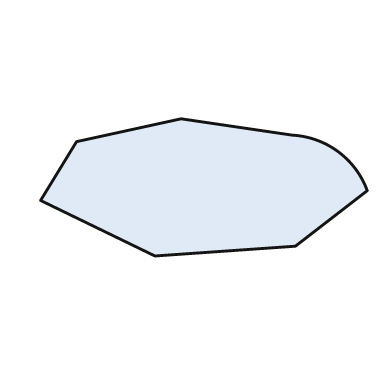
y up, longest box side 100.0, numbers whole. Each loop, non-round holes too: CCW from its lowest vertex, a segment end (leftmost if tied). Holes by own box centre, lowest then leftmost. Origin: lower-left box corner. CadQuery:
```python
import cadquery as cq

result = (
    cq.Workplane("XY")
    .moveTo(35.0, 0.0)
    .lineTo(78.0, 3.0)
    .lineTo(100.0, 20.0)
    .threePointArc((91.0, 32.0), (77.0, 37.0))
    .lineTo(43.0, 42.0)
    .lineTo(11.0, 35.0)
    .lineTo(0.0, 17.0)
    .close()
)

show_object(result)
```